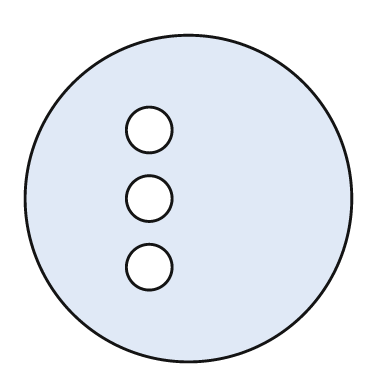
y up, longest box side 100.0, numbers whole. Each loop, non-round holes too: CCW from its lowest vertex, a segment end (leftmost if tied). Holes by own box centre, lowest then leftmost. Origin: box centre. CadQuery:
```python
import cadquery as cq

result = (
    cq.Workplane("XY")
    .moveTo(0.0, 0.0)
    .circle(50.0)
    .moveTo(-12.0, -21.0)
    .circle(7.0)
    .moveTo(-12.0, 0.0)
    .circle(7.0)
    .moveTo(-12.0, 21.0)
    .circle(7.0)
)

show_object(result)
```